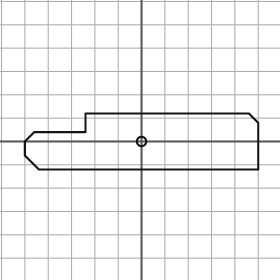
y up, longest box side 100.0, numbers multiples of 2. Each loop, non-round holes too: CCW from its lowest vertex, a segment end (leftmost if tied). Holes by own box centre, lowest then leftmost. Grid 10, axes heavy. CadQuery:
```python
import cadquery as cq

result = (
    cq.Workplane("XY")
    .moveTo(-44.0, -12.0)
    .lineTo(50.0, -12.0)
    .lineTo(50.0, 8.0)
    .lineTo(46.0, 12.0)
    .lineTo(-24.0, 12.0)
    .lineTo(-24.0, 4.0)
    .lineTo(-46.0, 4.0)
    .lineTo(-50.0, 0.0)
    .lineTo(-50.0, -6.0)
    .close()
    .moveTo(0.0, 0.0)
    .circle(2.0)
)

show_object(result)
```